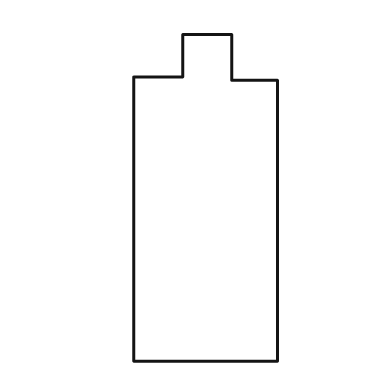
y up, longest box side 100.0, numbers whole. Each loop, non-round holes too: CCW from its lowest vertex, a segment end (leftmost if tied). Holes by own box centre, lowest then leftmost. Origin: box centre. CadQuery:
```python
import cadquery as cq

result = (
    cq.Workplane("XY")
    .moveTo(-22.0, -50.0)
    .lineTo(22.0, -50.0)
    .lineTo(22.0, 36.0)
    .lineTo(8.0, 36.0)
    .lineTo(8.0, 50.0)
    .lineTo(-7.0, 50.0)
    .lineTo(-7.0, 37.0)
    .lineTo(-22.0, 37.0)
    .close()
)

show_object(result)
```